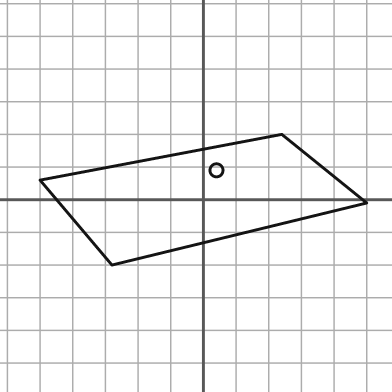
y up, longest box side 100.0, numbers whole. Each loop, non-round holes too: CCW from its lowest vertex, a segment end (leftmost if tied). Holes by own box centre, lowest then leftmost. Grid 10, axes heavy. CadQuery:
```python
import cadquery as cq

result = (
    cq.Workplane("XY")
    .moveTo(-28.0, -20.0)
    .lineTo(50.0, -1.0)
    .lineTo(24.0, 20.0)
    .lineTo(-50.0, 6.0)
    .close()
    .moveTo(4.0, 9.0)
    .circle(2.0)
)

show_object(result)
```